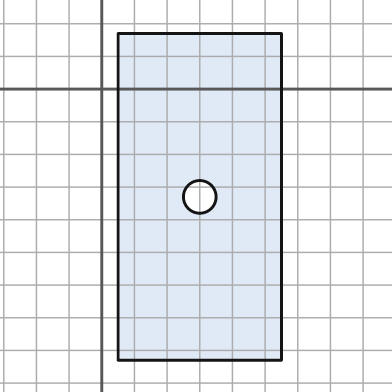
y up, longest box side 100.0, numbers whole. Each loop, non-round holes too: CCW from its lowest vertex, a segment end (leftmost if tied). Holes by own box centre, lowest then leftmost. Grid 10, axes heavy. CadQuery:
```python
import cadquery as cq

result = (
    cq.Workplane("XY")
    .moveTo(5.0, -83.0)
    .lineTo(55.0, -83.0)
    .lineTo(55.0, 17.0)
    .lineTo(5.0, 17.0)
    .close()
    .moveTo(30.0, -33.0)
    .circle(5.0)
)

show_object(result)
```